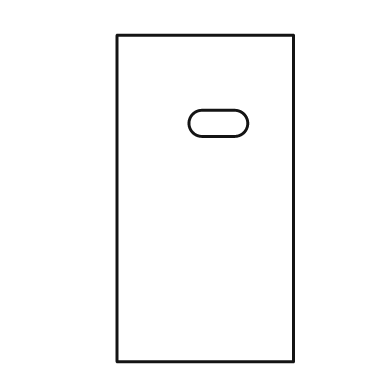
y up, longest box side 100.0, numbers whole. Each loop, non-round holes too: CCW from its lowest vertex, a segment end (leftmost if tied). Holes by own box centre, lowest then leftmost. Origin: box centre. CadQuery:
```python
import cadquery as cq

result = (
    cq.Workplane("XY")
    .moveTo(-27.0, -50.0)
    .lineTo(27.0, -50.0)
    .lineTo(27.0, 50.0)
    .lineTo(-27.0, 50.0)
    .close()
    .moveTo(-1.0, 19.0)
    .lineTo(9.0, 19.0)
    .threePointArc((13.0, 23.0), (9.0, 27.0))
    .lineTo(-1.0, 27.0)
    .threePointArc((-5.0, 23.0), (-1.0, 19.0))
    .close()
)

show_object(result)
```